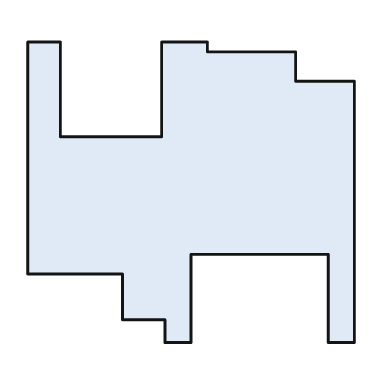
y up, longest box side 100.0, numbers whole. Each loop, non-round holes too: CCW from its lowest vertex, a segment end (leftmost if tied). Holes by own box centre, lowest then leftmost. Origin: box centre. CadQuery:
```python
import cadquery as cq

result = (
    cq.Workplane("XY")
    .moveTo(-8.0, -46.0)
    .lineTo(0.0, -46.0)
    .lineTo(0.0, -19.0)
    .lineTo(42.0, -19.0)
    .lineTo(42.0, -46.0)
    .lineTo(50.0, -46.0)
    .lineTo(50.0, 34.0)
    .lineTo(32.0, 34.0)
    .lineTo(32.0, 43.0)
    .lineTo(5.0, 43.0)
    .lineTo(5.0, 46.0)
    .lineTo(-9.0, 46.0)
    .lineTo(-9.0, 17.0)
    .lineTo(-40.0, 17.0)
    .lineTo(-40.0, 46.0)
    .lineTo(-50.0, 46.0)
    .lineTo(-50.0, -25.0)
    .lineTo(-21.0, -25.0)
    .lineTo(-21.0, -39.0)
    .lineTo(-8.0, -39.0)
    .close()
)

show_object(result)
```